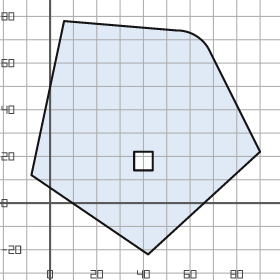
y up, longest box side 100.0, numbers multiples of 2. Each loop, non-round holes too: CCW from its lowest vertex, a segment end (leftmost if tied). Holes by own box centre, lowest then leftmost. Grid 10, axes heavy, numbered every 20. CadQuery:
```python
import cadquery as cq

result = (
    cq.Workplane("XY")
    .moveTo(42.0, -22.0)
    .lineTo(90.0, 22.0)
    .lineTo(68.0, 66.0)
    .threePointArc((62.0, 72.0), (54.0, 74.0))
    .lineTo(6.0, 78.0)
    .lineTo(-8.0, 12.0)
    .close()
    .moveTo(36.0, 14.0)
    .lineTo(44.0, 14.0)
    .lineTo(44.0, 22.0)
    .lineTo(36.0, 22.0)
    .close()
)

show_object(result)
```